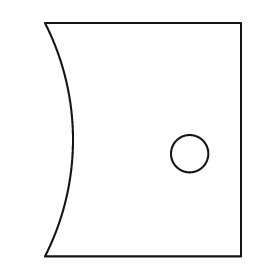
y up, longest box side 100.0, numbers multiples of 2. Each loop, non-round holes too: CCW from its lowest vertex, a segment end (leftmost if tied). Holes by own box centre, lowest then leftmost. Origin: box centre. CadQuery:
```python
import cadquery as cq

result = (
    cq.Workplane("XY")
    .moveTo(-42.0, -50.0)
    .lineTo(42.0, -50.0)
    .lineTo(42.0, 50.0)
    .lineTo(-42.0, 50.0)
    .threePointArc((-30.0, 0.0), (-42.0, -50.0))
    .close()
    .moveTo(20.0, -6.0)
    .circle(8.0)
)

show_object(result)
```